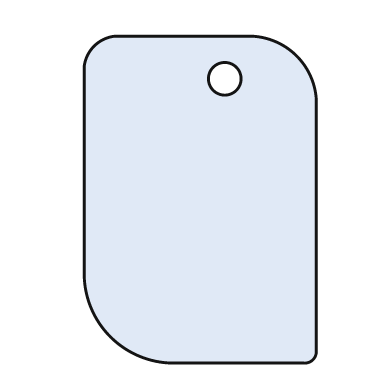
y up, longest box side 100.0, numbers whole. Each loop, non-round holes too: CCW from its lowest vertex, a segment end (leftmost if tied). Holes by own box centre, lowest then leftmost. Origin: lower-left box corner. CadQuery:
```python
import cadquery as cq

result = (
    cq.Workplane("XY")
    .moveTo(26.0, 0.0)
    .lineTo(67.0, 0.0)
    .threePointArc((70.0, 1.0), (71.0, 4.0))
    .lineTo(71.0, 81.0)
    .threePointArc((65.0, 94.0), (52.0, 100.0))
    .lineTo(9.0, 100.0)
    .threePointArc((3.0, 97.0), (0.0, 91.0))
    .lineTo(0.0, 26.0)
    .threePointArc((8.0, 8.0), (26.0, 0.0))
    .close()
    .moveTo(43.0, 87.0)
    .circle(5.0)
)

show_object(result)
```